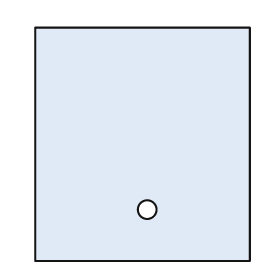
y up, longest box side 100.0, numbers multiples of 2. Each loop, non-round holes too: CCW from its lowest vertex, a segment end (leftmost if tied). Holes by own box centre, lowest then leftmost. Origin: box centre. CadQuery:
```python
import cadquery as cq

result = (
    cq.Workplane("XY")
    .moveTo(-46.0, -50.0)
    .lineTo(46.0, -50.0)
    .lineTo(46.0, 50.0)
    .lineTo(-46.0, 50.0)
    .close()
    .moveTo(2.0, -28.0)
    .circle(4.0)
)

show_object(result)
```